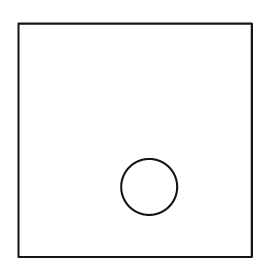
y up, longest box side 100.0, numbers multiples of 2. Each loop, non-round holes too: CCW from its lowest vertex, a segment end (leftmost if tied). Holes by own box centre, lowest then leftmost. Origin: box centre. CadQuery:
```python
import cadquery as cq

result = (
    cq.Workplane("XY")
    .moveTo(-50.0, -50.0)
    .lineTo(50.0, -50.0)
    .lineTo(50.0, 50.0)
    .lineTo(-50.0, 50.0)
    .close()
    .moveTo(6.0, -20.0)
    .circle(12.0)
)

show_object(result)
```